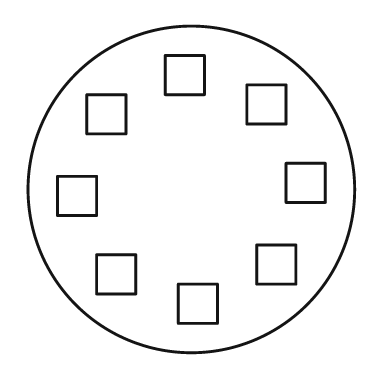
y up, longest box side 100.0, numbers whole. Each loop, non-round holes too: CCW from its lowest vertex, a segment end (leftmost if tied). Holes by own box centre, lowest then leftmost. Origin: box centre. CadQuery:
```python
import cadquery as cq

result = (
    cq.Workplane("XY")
    .moveTo(0.0, 0.0)
    .circle(50.0)
    .moveTo(-4.0, -41.0)
    .lineTo(8.0, -41.0)
    .lineTo(8.0, -29.0)
    .lineTo(-4.0, -29.0)
    .close()
    .moveTo(-29.0, -32.0)
    .lineTo(-17.0, -32.0)
    .lineTo(-17.0, -20.0)
    .lineTo(-29.0, -20.0)
    .close()
    .moveTo(20.0, -29.0)
    .lineTo(32.0, -29.0)
    .lineTo(32.0, -17.0)
    .lineTo(20.0, -17.0)
    .close()
    .moveTo(-41.0, -8.0)
    .lineTo(-29.0, -8.0)
    .lineTo(-29.0, 4.0)
    .lineTo(-41.0, 4.0)
    .close()
    .moveTo(29.0, -4.0)
    .lineTo(41.0, -4.0)
    .lineTo(41.0, 8.0)
    .lineTo(29.0, 8.0)
    .close()
    .moveTo(-32.0, 17.0)
    .lineTo(-20.0, 17.0)
    .lineTo(-20.0, 29.0)
    .lineTo(-32.0, 29.0)
    .close()
    .moveTo(17.0, 20.0)
    .lineTo(29.0, 20.0)
    .lineTo(29.0, 32.0)
    .lineTo(17.0, 32.0)
    .close()
    .moveTo(-8.0, 29.0)
    .lineTo(4.0, 29.0)
    .lineTo(4.0, 41.0)
    .lineTo(-8.0, 41.0)
    .close()
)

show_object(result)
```